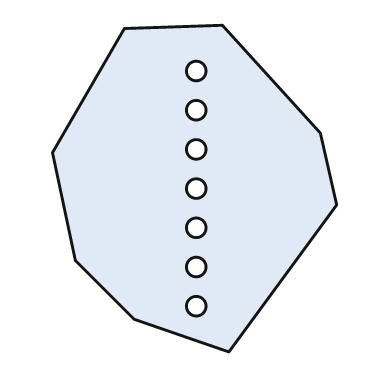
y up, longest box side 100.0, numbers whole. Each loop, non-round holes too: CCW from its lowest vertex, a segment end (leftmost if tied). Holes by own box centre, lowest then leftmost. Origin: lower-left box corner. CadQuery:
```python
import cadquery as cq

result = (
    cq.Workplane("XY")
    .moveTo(54.0, 0.0)
    .lineTo(87.0, 45.0)
    .lineTo(82.0, 67.0)
    .lineTo(52.0, 100.0)
    .lineTo(22.0, 99.0)
    .lineTo(0.0, 61.0)
    .lineTo(7.0, 28.0)
    .lineTo(25.0, 10.0)
    .close()
    .moveTo(44.0, 14.0)
    .circle(3.0)
    .moveTo(44.0, 26.0)
    .circle(3.0)
    .moveTo(44.0, 38.0)
    .circle(3.0)
    .moveTo(44.0, 50.0)
    .circle(3.0)
    .moveTo(44.0, 62.0)
    .circle(3.0)
    .moveTo(44.0, 74.0)
    .circle(3.0)
    .moveTo(44.0, 86.0)
    .circle(3.0)
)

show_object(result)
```